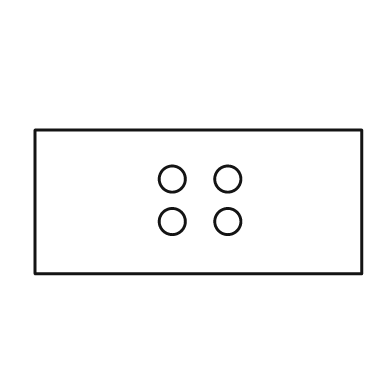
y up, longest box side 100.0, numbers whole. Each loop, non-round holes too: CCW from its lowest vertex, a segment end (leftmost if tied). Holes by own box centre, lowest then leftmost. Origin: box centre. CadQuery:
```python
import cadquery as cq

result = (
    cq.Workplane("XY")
    .moveTo(-50.0, -22.0)
    .lineTo(50.0, -22.0)
    .lineTo(50.0, 22.0)
    .lineTo(-50.0, 22.0)
    .close()
    .moveTo(-8.0, -6.0)
    .circle(4.0)
    .moveTo(9.0, -6.0)
    .circle(4.0)
    .moveTo(-8.0, 7.0)
    .circle(4.0)
    .moveTo(9.0, 7.0)
    .circle(4.0)
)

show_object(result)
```